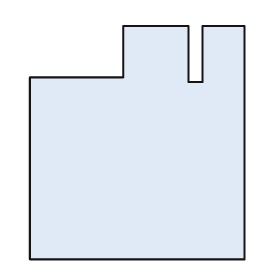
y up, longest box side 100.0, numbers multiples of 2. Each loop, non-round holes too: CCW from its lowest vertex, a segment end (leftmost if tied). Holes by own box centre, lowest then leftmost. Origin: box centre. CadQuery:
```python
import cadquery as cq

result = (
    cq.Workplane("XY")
    .moveTo(-46.0, -50.0)
    .lineTo(46.0, -50.0)
    .lineTo(46.0, 50.0)
    .lineTo(28.0, 50.0)
    .lineTo(28.0, 26.0)
    .lineTo(22.0, 26.0)
    .lineTo(22.0, 50.0)
    .lineTo(-6.0, 50.0)
    .lineTo(-6.0, 28.0)
    .lineTo(-46.0, 28.0)
    .close()
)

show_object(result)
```